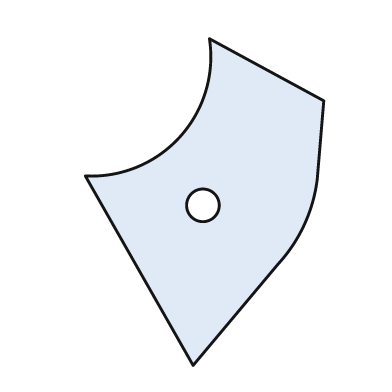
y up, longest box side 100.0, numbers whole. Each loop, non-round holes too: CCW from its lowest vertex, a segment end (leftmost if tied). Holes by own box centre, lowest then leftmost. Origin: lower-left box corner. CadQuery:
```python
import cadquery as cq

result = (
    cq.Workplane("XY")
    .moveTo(33.0, 0.0)
    .lineTo(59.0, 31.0)
    .threePointArc((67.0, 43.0), (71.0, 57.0))
    .lineTo(73.0, 81.0)
    .lineTo(38.0, 100.0)
    .threePointArc((29.0, 70.0), (0.0, 58.0))
    .close()
    .moveTo(36.0, 49.0)
    .circle(5.0)
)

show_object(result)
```